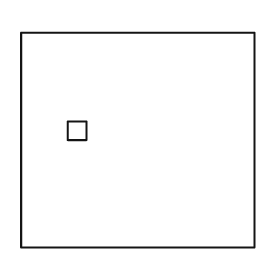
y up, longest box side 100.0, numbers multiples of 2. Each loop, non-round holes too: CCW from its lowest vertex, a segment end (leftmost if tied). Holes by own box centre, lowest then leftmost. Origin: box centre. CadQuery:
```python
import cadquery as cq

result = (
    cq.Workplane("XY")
    .moveTo(-50.0, -46.0)
    .lineTo(50.0, -46.0)
    .lineTo(50.0, 46.0)
    .lineTo(-50.0, 46.0)
    .close()
    .moveTo(-30.0, 0.0)
    .lineTo(-22.0, 0.0)
    .lineTo(-22.0, 8.0)
    .lineTo(-30.0, 8.0)
    .close()
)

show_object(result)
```